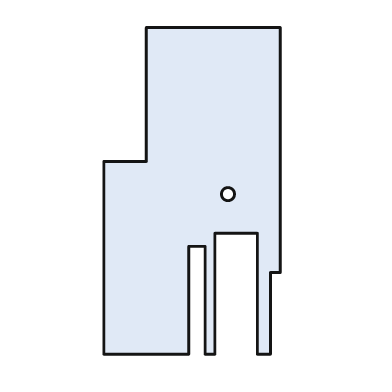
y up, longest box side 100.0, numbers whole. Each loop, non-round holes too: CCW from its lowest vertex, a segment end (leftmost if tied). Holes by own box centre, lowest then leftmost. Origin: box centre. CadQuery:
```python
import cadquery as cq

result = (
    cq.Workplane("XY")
    .moveTo(-27.0, -50.0)
    .lineTo(-1.0, -50.0)
    .lineTo(-1.0, -17.0)
    .lineTo(4.0, -17.0)
    .lineTo(4.0, -50.0)
    .lineTo(7.0, -50.0)
    .lineTo(7.0, -13.0)
    .lineTo(20.0, -13.0)
    .lineTo(20.0, -50.0)
    .lineTo(24.0, -50.0)
    .lineTo(24.0, -25.0)
    .lineTo(27.0, -25.0)
    .lineTo(27.0, 50.0)
    .lineTo(-14.0, 50.0)
    .lineTo(-14.0, 9.0)
    .lineTo(-27.0, 9.0)
    .close()
    .moveTo(11.0, -1.0)
    .circle(2.0)
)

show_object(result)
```